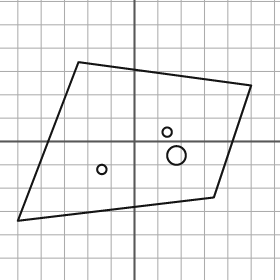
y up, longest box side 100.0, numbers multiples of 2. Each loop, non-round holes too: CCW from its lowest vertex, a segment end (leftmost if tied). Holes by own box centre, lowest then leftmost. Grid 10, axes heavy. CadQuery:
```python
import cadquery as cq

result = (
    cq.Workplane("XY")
    .moveTo(-50.0, -34.0)
    .lineTo(34.0, -24.0)
    .lineTo(50.0, 24.0)
    .lineTo(-24.0, 34.0)
    .close()
    .moveTo(-14.0, -12.0)
    .circle(2.0)
    .moveTo(18.0, -6.0)
    .circle(4.0)
    .moveTo(14.0, 4.0)
    .circle(2.0)
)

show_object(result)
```